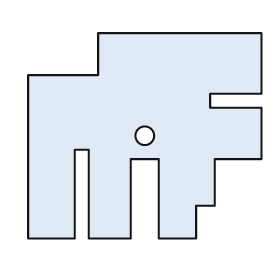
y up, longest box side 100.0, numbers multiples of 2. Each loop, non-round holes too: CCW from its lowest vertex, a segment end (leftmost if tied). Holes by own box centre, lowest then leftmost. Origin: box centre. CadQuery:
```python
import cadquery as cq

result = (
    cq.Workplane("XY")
    .moveTo(-50.0, -44.0)
    .lineTo(-30.0, -44.0)
    .lineTo(-30.0, -6.0)
    .lineTo(-24.0, -6.0)
    .lineTo(-24.0, -44.0)
    .lineTo(-6.0, -44.0)
    .lineTo(-6.0, -10.0)
    .lineTo(6.0, -10.0)
    .lineTo(6.0, -44.0)
    .lineTo(22.0, -44.0)
    .lineTo(22.0, -30.0)
    .lineTo(30.0, -30.0)
    .lineTo(30.0, -10.0)
    .lineTo(50.0, -10.0)
    .lineTo(50.0, 12.0)
    .lineTo(28.0, 12.0)
    .lineTo(28.0, 18.0)
    .lineTo(50.0, 18.0)
    .lineTo(50.0, 44.0)
    .lineTo(-20.0, 44.0)
    .lineTo(-20.0, 26.0)
    .lineTo(-50.0, 26.0)
    .close()
    .moveTo(0.0, 0.0)
    .circle(4.0)
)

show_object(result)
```